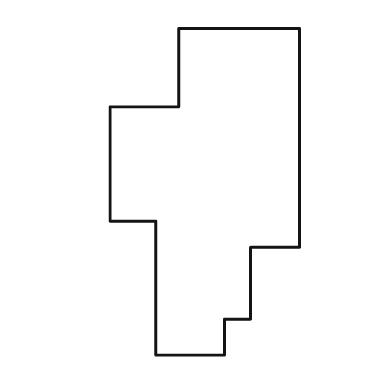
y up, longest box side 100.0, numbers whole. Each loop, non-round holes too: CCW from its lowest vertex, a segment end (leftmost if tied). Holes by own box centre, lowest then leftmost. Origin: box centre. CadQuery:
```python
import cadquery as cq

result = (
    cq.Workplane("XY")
    .moveTo(-15.0, -50.0)
    .lineTo(6.0, -50.0)
    .lineTo(6.0, -39.0)
    .lineTo(14.0, -39.0)
    .lineTo(14.0, -17.0)
    .lineTo(29.0, -17.0)
    .lineTo(29.0, 50.0)
    .lineTo(-8.0, 50.0)
    .lineTo(-8.0, 26.0)
    .lineTo(-29.0, 26.0)
    .lineTo(-29.0, -9.0)
    .lineTo(-15.0, -9.0)
    .close()
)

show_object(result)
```